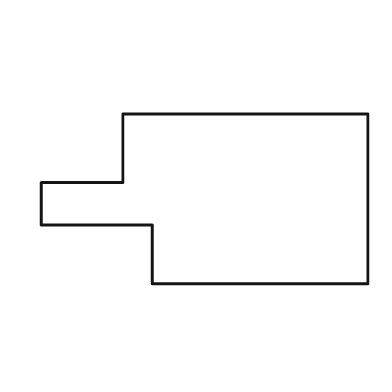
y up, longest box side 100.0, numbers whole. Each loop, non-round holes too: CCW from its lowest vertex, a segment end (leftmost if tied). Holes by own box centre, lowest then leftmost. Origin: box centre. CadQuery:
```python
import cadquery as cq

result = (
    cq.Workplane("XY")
    .moveTo(-16.0, -26.0)
    .lineTo(50.0, -26.0)
    .lineTo(50.0, 26.0)
    .lineTo(-25.0, 26.0)
    .lineTo(-25.0, 5.0)
    .lineTo(-50.0, 5.0)
    .lineTo(-50.0, -8.0)
    .lineTo(-16.0, -8.0)
    .close()
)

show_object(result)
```